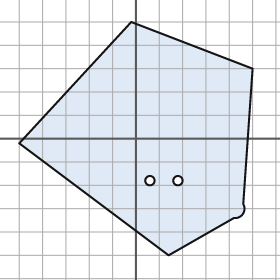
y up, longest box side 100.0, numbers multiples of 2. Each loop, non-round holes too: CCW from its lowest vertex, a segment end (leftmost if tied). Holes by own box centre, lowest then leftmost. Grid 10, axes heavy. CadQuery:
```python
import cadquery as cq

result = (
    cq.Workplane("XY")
    .moveTo(14.0, -50.0)
    .lineTo(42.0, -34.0)
    .threePointArc((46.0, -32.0), (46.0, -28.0))
    .lineTo(50.0, 30.0)
    .lineTo(-2.0, 50.0)
    .lineTo(-50.0, -2.0)
    .close()
    .moveTo(6.0, -18.0)
    .circle(2.0)
    .moveTo(18.0, -18.0)
    .circle(2.0)
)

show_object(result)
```